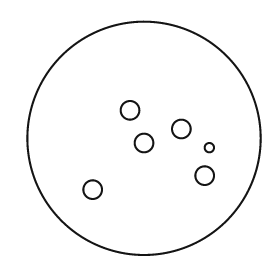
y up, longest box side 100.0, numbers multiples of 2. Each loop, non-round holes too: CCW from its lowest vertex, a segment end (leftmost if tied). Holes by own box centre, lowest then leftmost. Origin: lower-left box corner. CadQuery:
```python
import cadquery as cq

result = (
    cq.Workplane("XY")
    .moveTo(50.0, 50.0)
    .circle(50.0)
    .moveTo(28.0, 28.0)
    .circle(4.0)
    .moveTo(76.0, 34.0)
    .circle(4.0)
    .moveTo(78.0, 46.0)
    .circle(2.0)
    .moveTo(50.0, 48.0)
    .circle(4.0)
    .moveTo(66.0, 54.0)
    .circle(4.0)
    .moveTo(44.0, 62.0)
    .circle(4.0)
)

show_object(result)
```